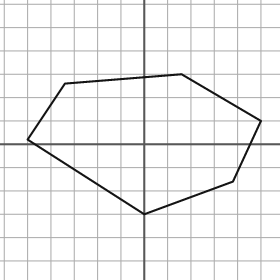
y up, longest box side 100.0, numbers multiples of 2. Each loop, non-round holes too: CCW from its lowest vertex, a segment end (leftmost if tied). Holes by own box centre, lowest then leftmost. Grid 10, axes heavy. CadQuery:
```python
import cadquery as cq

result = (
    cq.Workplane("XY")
    .moveTo(0.0, -30.0)
    .lineTo(38.0, -16.0)
    .lineTo(50.0, 10.0)
    .lineTo(16.0, 30.0)
    .lineTo(-34.0, 26.0)
    .lineTo(-50.0, 2.0)
    .close()
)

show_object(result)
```